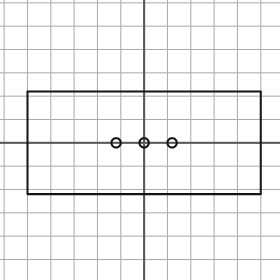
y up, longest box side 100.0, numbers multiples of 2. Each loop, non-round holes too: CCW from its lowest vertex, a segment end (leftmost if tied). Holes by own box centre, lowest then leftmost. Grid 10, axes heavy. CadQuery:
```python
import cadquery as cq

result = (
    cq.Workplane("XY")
    .moveTo(-50.0, -22.0)
    .lineTo(50.0, -22.0)
    .lineTo(50.0, 22.0)
    .lineTo(-50.0, 22.0)
    .close()
    .moveTo(-12.0, 0.0)
    .circle(2.0)
    .moveTo(0.0, 0.0)
    .circle(2.0)
    .moveTo(12.0, 0.0)
    .circle(2.0)
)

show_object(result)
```